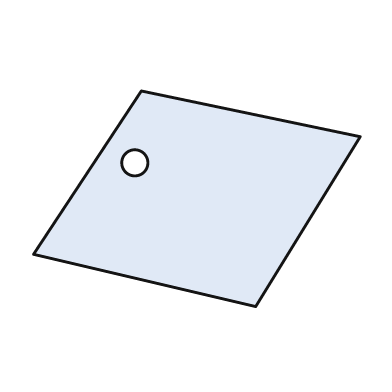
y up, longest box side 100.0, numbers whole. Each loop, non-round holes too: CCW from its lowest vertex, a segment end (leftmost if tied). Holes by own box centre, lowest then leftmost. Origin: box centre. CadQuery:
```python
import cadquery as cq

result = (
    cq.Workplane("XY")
    .moveTo(18.0, -33.0)
    .lineTo(50.0, 19.0)
    .lineTo(-17.0, 33.0)
    .lineTo(-50.0, -17.0)
    .close()
    .moveTo(-19.0, 11.0)
    .circle(4.0)
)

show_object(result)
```